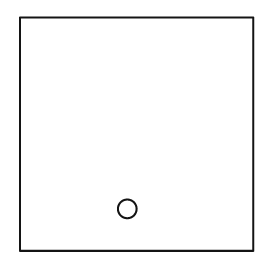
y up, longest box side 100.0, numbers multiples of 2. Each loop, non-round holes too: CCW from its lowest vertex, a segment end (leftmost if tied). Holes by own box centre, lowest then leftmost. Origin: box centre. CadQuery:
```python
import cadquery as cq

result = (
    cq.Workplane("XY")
    .moveTo(-50.0, -50.0)
    .lineTo(50.0, -50.0)
    .lineTo(50.0, 50.0)
    .lineTo(-50.0, 50.0)
    .close()
    .moveTo(-4.0, -32.0)
    .circle(4.0)
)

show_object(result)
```